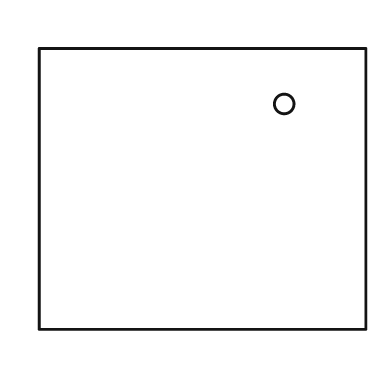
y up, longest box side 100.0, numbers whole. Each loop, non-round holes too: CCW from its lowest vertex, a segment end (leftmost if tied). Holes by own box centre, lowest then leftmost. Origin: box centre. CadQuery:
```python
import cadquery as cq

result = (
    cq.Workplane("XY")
    .moveTo(-50.0, -43.0)
    .lineTo(50.0, -43.0)
    .lineTo(50.0, 43.0)
    .lineTo(-50.0, 43.0)
    .close()
    .moveTo(25.0, 26.0)
    .circle(3.0)
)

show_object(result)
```